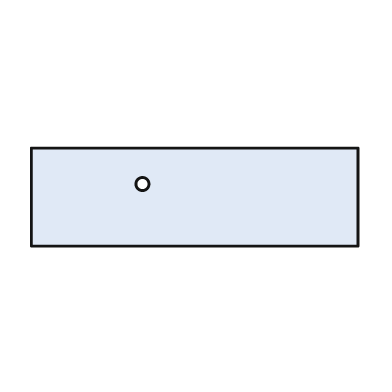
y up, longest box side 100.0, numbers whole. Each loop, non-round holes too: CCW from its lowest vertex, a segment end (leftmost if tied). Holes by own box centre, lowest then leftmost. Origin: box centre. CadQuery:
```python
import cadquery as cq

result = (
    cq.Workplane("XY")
    .moveTo(-50.0, -15.0)
    .lineTo(50.0, -15.0)
    .lineTo(50.0, 15.0)
    .lineTo(-50.0, 15.0)
    .close()
    .moveTo(-16.0, 4.0)
    .circle(2.0)
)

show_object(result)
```